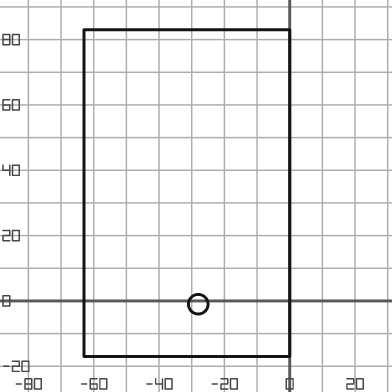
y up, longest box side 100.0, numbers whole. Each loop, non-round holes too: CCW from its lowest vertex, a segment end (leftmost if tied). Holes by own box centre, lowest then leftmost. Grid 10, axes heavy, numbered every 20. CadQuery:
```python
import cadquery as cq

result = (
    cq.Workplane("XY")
    .moveTo(-63.0, -17.0)
    .lineTo(0.0, -17.0)
    .lineTo(0.0, 83.0)
    .lineTo(-63.0, 83.0)
    .close()
    .moveTo(-28.0, -1.0)
    .circle(3.0)
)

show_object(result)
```